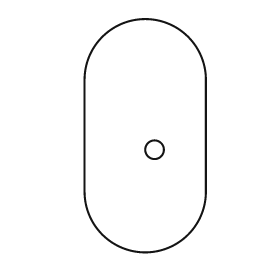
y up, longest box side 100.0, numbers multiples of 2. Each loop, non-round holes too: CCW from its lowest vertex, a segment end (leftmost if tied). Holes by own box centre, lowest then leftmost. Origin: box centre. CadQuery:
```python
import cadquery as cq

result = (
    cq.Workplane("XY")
    .moveTo(-26.0, -24.0)
    .threePointArc((0.0, -50.0), (26.0, -24.0))
    .lineTo(26.0, 24.0)
    .threePointArc((0.0, 50.0), (-26.0, 24.0))
    .close()
    .moveTo(4.0, -6.0)
    .circle(4.0)
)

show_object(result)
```